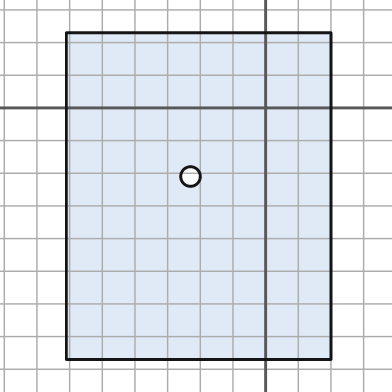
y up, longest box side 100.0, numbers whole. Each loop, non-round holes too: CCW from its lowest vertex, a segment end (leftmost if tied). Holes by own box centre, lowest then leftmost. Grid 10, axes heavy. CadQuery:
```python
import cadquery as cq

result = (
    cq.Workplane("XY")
    .moveTo(-61.0, -77.0)
    .lineTo(20.0, -77.0)
    .lineTo(20.0, 23.0)
    .lineTo(-61.0, 23.0)
    .close()
    .moveTo(-23.0, -21.0)
    .circle(3.0)
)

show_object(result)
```